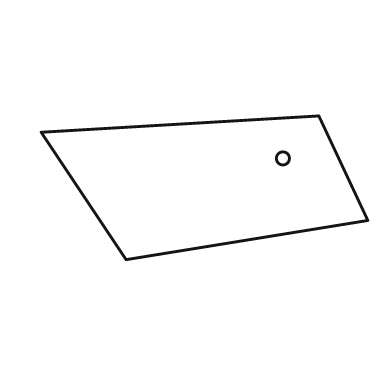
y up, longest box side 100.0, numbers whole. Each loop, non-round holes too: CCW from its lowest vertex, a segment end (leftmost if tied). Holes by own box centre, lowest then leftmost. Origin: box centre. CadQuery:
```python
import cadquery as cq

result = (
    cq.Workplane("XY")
    .moveTo(-24.0, -22.0)
    .lineTo(50.0, -10.0)
    .lineTo(35.0, 22.0)
    .lineTo(-50.0, 17.0)
    .close()
    .moveTo(24.0, 9.0)
    .circle(2.0)
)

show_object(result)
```